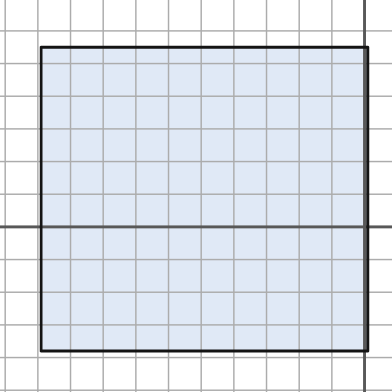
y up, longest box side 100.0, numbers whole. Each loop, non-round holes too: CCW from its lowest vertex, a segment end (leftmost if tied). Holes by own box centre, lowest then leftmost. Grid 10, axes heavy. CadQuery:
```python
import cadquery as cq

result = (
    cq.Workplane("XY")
    .moveTo(-99.0, -38.0)
    .lineTo(1.0, -38.0)
    .lineTo(1.0, 55.0)
    .lineTo(-99.0, 55.0)
    .close()
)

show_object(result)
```